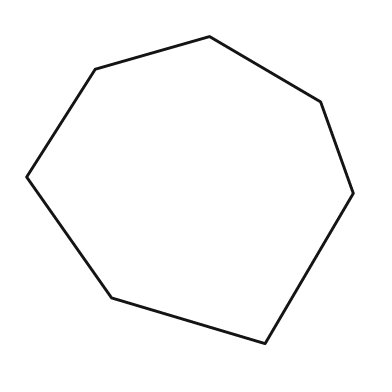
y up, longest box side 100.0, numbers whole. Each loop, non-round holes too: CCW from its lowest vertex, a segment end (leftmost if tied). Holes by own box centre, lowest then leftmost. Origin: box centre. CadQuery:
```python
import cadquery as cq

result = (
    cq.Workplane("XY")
    .moveTo(23.0, -47.0)
    .lineTo(50.0, -1.0)
    .lineTo(40.0, 27.0)
    .lineTo(6.0, 47.0)
    .lineTo(-29.0, 37.0)
    .lineTo(-50.0, 4.0)
    .lineTo(-24.0, -33.0)
    .close()
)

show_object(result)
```